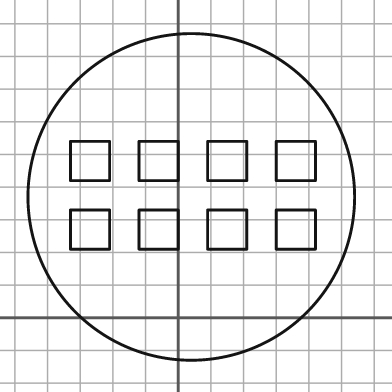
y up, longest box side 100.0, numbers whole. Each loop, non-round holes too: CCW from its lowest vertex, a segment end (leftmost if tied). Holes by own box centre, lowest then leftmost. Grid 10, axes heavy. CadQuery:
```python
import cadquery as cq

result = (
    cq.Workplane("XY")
    .moveTo(4.0, 37.0)
    .circle(50.0)
    .moveTo(-33.0, 21.0)
    .lineTo(-21.0, 21.0)
    .lineTo(-21.0, 33.0)
    .lineTo(-33.0, 33.0)
    .close()
    .moveTo(-12.0, 21.0)
    .lineTo(0.0, 21.0)
    .lineTo(0.0, 33.0)
    .lineTo(-12.0, 33.0)
    .close()
    .moveTo(9.0, 21.0)
    .lineTo(21.0, 21.0)
    .lineTo(21.0, 33.0)
    .lineTo(9.0, 33.0)
    .close()
    .moveTo(30.0, 21.0)
    .lineTo(42.0, 21.0)
    .lineTo(42.0, 33.0)
    .lineTo(30.0, 33.0)
    .close()
    .moveTo(-33.0, 42.0)
    .lineTo(-21.0, 42.0)
    .lineTo(-21.0, 54.0)
    .lineTo(-33.0, 54.0)
    .close()
    .moveTo(-12.0, 42.0)
    .lineTo(0.0, 42.0)
    .lineTo(0.0, 54.0)
    .lineTo(-12.0, 54.0)
    .close()
    .moveTo(9.0, 42.0)
    .lineTo(21.0, 42.0)
    .lineTo(21.0, 54.0)
    .lineTo(9.0, 54.0)
    .close()
    .moveTo(30.0, 42.0)
    .lineTo(42.0, 42.0)
    .lineTo(42.0, 54.0)
    .lineTo(30.0, 54.0)
    .close()
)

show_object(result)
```